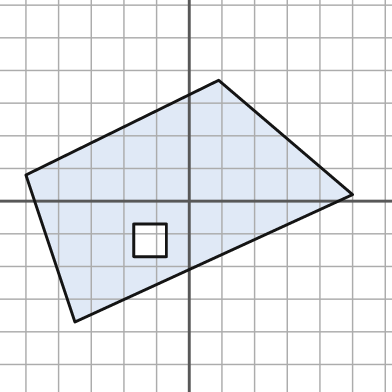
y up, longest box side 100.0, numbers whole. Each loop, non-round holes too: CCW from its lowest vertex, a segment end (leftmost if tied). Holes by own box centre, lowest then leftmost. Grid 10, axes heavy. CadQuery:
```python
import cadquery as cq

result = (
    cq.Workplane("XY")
    .moveTo(-35.0, -37.0)
    .lineTo(50.0, 2.0)
    .lineTo(9.0, 37.0)
    .lineTo(-50.0, 8.0)
    .close()
    .moveTo(-17.0, -17.0)
    .lineTo(-7.0, -17.0)
    .lineTo(-7.0, -7.0)
    .lineTo(-17.0, -7.0)
    .close()
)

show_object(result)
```